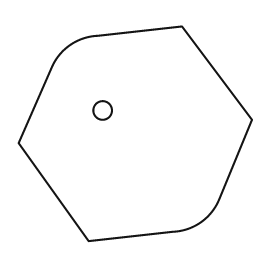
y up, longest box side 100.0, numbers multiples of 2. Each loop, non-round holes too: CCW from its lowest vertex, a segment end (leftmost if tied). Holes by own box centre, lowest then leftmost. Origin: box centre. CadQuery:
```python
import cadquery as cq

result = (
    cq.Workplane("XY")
    .moveTo(-20.0, -46.0)
    .lineTo(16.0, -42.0)
    .threePointArc((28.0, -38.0), (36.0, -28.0))
    .lineTo(50.0, 6.0)
    .lineTo(20.0, 46.0)
    .lineTo(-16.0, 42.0)
    .threePointArc((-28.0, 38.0), (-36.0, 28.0))
    .lineTo(-50.0, -4.0)
    .close()
    .moveTo(-14.0, 10.0)
    .circle(4.0)
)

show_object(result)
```